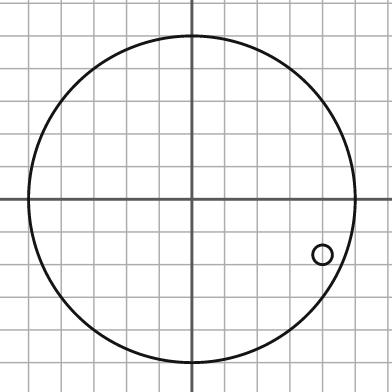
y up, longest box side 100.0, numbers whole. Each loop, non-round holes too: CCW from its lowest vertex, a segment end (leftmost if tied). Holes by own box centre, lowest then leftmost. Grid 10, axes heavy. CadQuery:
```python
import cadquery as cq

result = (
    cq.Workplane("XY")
    .moveTo(0.0, 0.0)
    .circle(50.0)
    .moveTo(40.0, -17.0)
    .circle(3.0)
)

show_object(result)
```